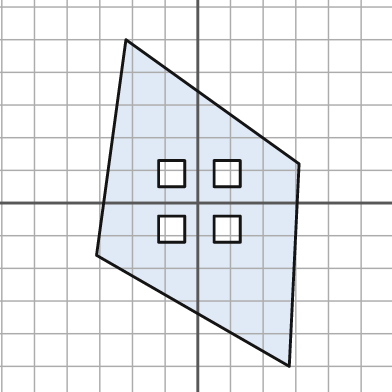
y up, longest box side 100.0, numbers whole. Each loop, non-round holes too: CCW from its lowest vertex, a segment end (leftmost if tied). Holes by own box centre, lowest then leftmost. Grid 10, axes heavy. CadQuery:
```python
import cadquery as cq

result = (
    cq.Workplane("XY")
    .moveTo(28.0, -50.0)
    .lineTo(31.0, 12.0)
    .lineTo(-22.0, 50.0)
    .lineTo(-31.0, -16.0)
    .close()
    .moveTo(-12.0, -12.0)
    .lineTo(-4.0, -12.0)
    .lineTo(-4.0, -4.0)
    .lineTo(-12.0, -4.0)
    .close()
    .moveTo(5.0, -12.0)
    .lineTo(13.0, -12.0)
    .lineTo(13.0, -4.0)
    .lineTo(5.0, -4.0)
    .close()
    .moveTo(-12.0, 5.0)
    .lineTo(-4.0, 5.0)
    .lineTo(-4.0, 13.0)
    .lineTo(-12.0, 13.0)
    .close()
    .moveTo(5.0, 5.0)
    .lineTo(13.0, 5.0)
    .lineTo(13.0, 13.0)
    .lineTo(5.0, 13.0)
    .close()
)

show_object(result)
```